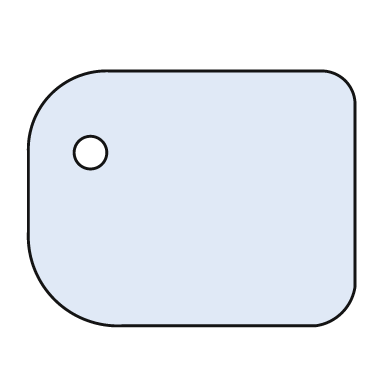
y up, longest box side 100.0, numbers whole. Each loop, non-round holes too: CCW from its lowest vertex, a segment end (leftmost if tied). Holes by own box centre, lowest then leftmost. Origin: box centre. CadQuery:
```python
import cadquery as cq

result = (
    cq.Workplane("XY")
    .moveTo(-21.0, -39.0)
    .lineTo(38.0, -39.0)
    .threePointArc((46.0, -35.0), (50.0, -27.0))
    .lineTo(50.0, 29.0)
    .threePointArc((47.0, 36.0), (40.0, 39.0))
    .lineTo(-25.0, 39.0)
    .threePointArc((-43.0, 32.0), (-50.0, 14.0))
    .lineTo(-50.0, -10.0)
    .threePointArc((-42.0, -31.0), (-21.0, -39.0))
    .close()
    .moveTo(-31.0, 14.0)
    .circle(5.0)
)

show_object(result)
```